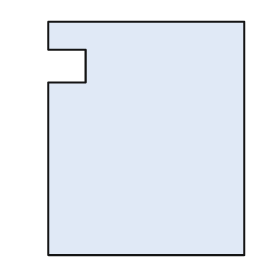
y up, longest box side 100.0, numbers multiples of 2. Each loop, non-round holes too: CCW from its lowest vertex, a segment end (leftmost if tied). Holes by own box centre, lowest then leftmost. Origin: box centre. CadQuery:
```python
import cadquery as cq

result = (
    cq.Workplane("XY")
    .moveTo(-42.0, -50.0)
    .lineTo(42.0, -50.0)
    .lineTo(42.0, 50.0)
    .lineTo(-42.0, 50.0)
    .lineTo(-42.0, 38.0)
    .lineTo(-26.0, 38.0)
    .lineTo(-26.0, 24.0)
    .lineTo(-42.0, 24.0)
    .close()
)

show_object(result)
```